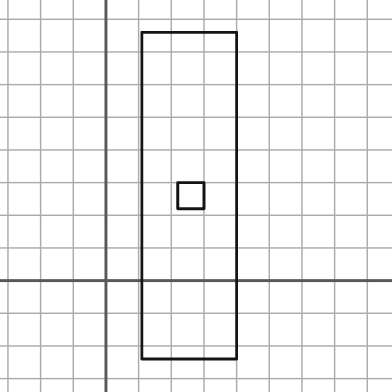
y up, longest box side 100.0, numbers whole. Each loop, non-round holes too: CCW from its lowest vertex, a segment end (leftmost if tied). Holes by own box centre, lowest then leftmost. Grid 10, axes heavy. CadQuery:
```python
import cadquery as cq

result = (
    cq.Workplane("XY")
    .moveTo(11.0, -24.0)
    .lineTo(40.0, -24.0)
    .lineTo(40.0, 76.0)
    .lineTo(11.0, 76.0)
    .close()
    .moveTo(22.0, 22.0)
    .lineTo(30.0, 22.0)
    .lineTo(30.0, 30.0)
    .lineTo(22.0, 30.0)
    .close()
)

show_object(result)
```